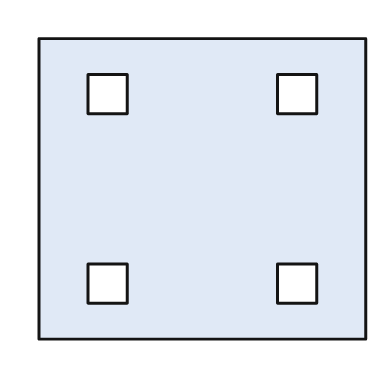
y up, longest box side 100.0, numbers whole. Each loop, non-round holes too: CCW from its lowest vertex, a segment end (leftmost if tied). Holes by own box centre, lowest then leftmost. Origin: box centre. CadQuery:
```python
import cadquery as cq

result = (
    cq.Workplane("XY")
    .moveTo(-50.0, -46.0)
    .lineTo(50.0, -46.0)
    .lineTo(50.0, 46.0)
    .lineTo(-50.0, 46.0)
    .close()
    .moveTo(-35.0, -35.0)
    .lineTo(-23.0, -35.0)
    .lineTo(-23.0, -23.0)
    .lineTo(-35.0, -23.0)
    .close()
    .moveTo(23.0, -35.0)
    .lineTo(35.0, -35.0)
    .lineTo(35.0, -23.0)
    .lineTo(23.0, -23.0)
    .close()
    .moveTo(-35.0, 23.0)
    .lineTo(-23.0, 23.0)
    .lineTo(-23.0, 35.0)
    .lineTo(-35.0, 35.0)
    .close()
    .moveTo(23.0, 23.0)
    .lineTo(35.0, 23.0)
    .lineTo(35.0, 35.0)
    .lineTo(23.0, 35.0)
    .close()
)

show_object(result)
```